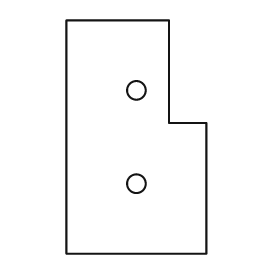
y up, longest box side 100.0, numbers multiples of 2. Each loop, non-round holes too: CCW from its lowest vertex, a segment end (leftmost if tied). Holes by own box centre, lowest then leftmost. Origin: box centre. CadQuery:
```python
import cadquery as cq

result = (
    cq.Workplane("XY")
    .moveTo(-30.0, -50.0)
    .lineTo(30.0, -50.0)
    .lineTo(30.0, 6.0)
    .lineTo(14.0, 6.0)
    .lineTo(14.0, 50.0)
    .lineTo(-30.0, 50.0)
    .close()
    .moveTo(0.0, -20.0)
    .circle(4.0)
    .moveTo(0.0, 20.0)
    .circle(4.0)
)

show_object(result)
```